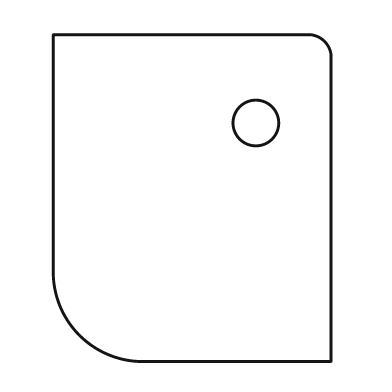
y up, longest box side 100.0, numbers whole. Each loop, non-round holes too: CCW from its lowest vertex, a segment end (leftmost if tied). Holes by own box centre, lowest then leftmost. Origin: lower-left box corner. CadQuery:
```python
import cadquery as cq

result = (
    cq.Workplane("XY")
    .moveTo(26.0, 0.0)
    .lineTo(85.0, 0.0)
    .lineTo(85.0, 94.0)
    .threePointArc((83.0, 98.0), (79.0, 100.0))
    .lineTo(0.0, 100.0)
    .lineTo(0.0, 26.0)
    .threePointArc((8.0, 8.0), (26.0, 0.0))
    .close()
    .moveTo(62.0, 73.0)
    .circle(7.0)
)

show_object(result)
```